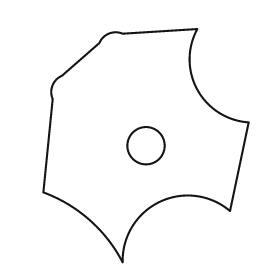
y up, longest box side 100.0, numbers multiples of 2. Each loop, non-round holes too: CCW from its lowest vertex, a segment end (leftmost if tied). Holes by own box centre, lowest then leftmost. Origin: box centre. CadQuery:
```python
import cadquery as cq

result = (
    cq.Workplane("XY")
    .moveTo(-10.0, -50.0)
    .threePointArc((6.0, -24.0), (36.0, -28.0))
    .lineTo(44.0, 10.0)
    .threePointArc((22.0, 24.0), (22.0, 50.0))
    .lineTo(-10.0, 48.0)
    .threePointArc((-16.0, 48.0), (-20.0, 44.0))
    .lineTo(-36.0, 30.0)
    .threePointArc((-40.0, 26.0), (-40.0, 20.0))
    .lineTo(-44.0, -20.0)
    .threePointArc((-24.0, -32.0), (-10.0, -50.0))
    .close()
    .moveTo(0.0, 0.0)
    .circle(8.0)
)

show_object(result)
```